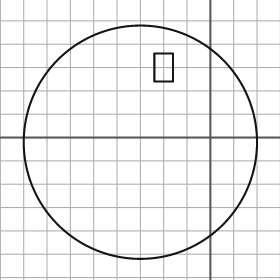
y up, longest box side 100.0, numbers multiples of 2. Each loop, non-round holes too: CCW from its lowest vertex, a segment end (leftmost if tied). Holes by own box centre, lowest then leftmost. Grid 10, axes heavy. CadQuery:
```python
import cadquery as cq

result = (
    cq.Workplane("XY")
    .moveTo(-30.0, -2.0)
    .circle(50.0)
    .moveTo(-24.0, 24.0)
    .lineTo(-16.0, 24.0)
    .lineTo(-16.0, 36.0)
    .lineTo(-24.0, 36.0)
    .close()
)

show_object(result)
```